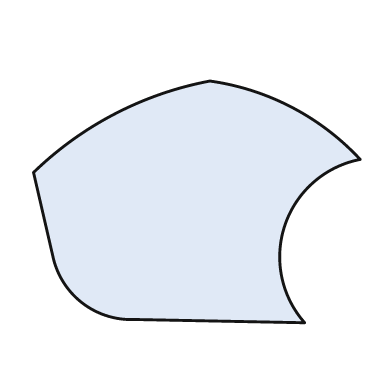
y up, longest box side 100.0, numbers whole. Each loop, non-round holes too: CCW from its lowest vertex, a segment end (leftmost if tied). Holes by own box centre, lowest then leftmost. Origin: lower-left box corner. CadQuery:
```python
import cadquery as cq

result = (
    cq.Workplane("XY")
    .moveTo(83.0, 0.0)
    .threePointArc((77.0, 30.0), (100.0, 50.0))
    .threePointArc((79.0, 66.0), (54.0, 74.0))
    .threePointArc((25.0, 64.0), (0.0, 46.0))
    .lineTo(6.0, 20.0)
    .threePointArc((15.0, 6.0), (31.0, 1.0))
    .close()
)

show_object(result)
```